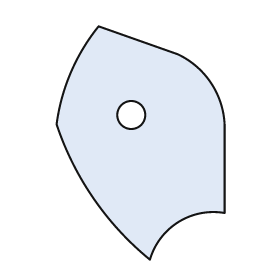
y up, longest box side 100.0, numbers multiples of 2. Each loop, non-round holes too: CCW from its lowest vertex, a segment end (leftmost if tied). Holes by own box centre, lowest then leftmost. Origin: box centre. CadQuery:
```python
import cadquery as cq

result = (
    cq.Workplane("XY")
    .moveTo(4.0, -50.0)
    .threePointArc((16.0, -34.0), (36.0, -30.0))
    .lineTo(36.0, 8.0)
    .threePointArc((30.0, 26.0), (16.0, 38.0))
    .lineTo(-18.0, 50.0)
    .threePointArc((-30.0, 30.0), (-36.0, 8.0))
    .threePointArc((-20.0, -24.0), (4.0, -50.0))
    .close()
    .moveTo(-4.0, 12.0)
    .circle(6.0)
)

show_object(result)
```